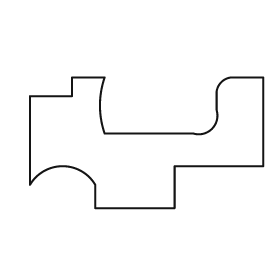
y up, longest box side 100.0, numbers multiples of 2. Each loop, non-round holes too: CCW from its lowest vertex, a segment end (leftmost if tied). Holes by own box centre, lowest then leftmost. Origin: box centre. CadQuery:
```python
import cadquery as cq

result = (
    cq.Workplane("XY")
    .moveTo(-22.0, -28.0)
    .lineTo(12.0, -28.0)
    .lineTo(12.0, -10.0)
    .lineTo(50.0, -10.0)
    .lineTo(50.0, 28.0)
    .lineTo(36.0, 28.0)
    .threePointArc((32.0, 26.0), (30.0, 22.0))
    .lineTo(30.0, 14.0)
    .threePointArc((28.0, 6.0), (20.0, 4.0))
    .lineTo(-18.0, 4.0)
    .threePointArc((-20.0, 16.0), (-18.0, 28.0))
    .lineTo(-32.0, 28.0)
    .lineTo(-32.0, 20.0)
    .lineTo(-50.0, 20.0)
    .lineTo(-50.0, -18.0)
    .threePointArc((-36.0, -10.0), (-22.0, -18.0))
    .close()
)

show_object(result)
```